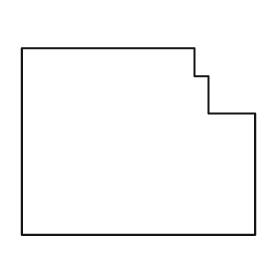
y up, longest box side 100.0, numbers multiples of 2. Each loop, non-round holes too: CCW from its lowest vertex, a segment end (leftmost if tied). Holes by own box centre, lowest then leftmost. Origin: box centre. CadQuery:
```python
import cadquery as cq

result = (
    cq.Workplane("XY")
    .moveTo(-50.0, -40.0)
    .lineTo(50.0, -40.0)
    .lineTo(50.0, 12.0)
    .lineTo(30.0, 12.0)
    .lineTo(30.0, 28.0)
    .lineTo(24.0, 28.0)
    .lineTo(24.0, 40.0)
    .lineTo(-50.0, 40.0)
    .close()
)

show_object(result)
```